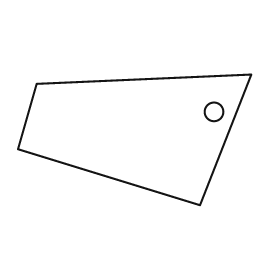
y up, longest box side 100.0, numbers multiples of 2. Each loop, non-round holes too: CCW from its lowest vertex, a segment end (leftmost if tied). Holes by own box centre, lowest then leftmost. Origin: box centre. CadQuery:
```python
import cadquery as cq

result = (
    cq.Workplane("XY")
    .moveTo(28.0, -28.0)
    .lineTo(50.0, 28.0)
    .lineTo(-42.0, 24.0)
    .lineTo(-50.0, -4.0)
    .close()
    .moveTo(34.0, 12.0)
    .circle(4.0)
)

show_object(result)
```